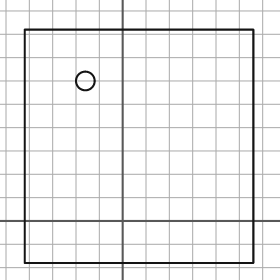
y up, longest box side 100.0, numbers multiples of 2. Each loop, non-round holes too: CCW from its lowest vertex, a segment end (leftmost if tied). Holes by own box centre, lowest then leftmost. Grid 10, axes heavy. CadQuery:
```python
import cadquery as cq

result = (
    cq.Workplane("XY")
    .moveTo(-42.0, -18.0)
    .lineTo(56.0, -18.0)
    .lineTo(56.0, 82.0)
    .lineTo(-42.0, 82.0)
    .close()
    .moveTo(-16.0, 60.0)
    .circle(4.0)
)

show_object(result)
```